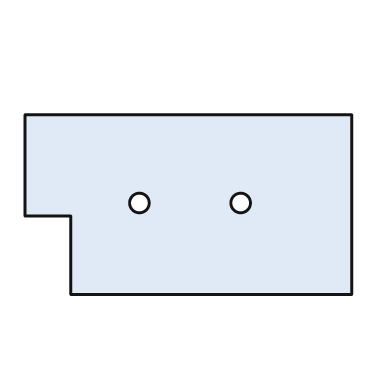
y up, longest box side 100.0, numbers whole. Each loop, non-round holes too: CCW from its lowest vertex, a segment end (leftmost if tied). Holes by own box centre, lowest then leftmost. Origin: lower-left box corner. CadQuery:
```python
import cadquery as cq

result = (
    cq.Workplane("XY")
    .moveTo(14.0, 0.0)
    .lineTo(100.0, 0.0)
    .lineTo(100.0, 55.0)
    .lineTo(0.0, 55.0)
    .lineTo(0.0, 24.0)
    .lineTo(14.0, 24.0)
    .close()
    .moveTo(35.0, 28.0)
    .circle(3.0)
    .moveTo(66.0, 28.0)
    .circle(3.0)
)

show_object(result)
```